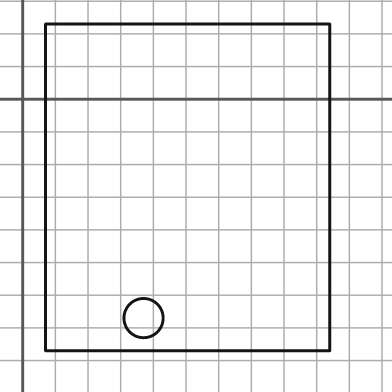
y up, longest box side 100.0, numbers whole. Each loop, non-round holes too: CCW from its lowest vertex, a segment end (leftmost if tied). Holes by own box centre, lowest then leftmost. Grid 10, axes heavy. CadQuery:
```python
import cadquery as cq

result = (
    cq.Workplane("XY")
    .moveTo(7.0, -77.0)
    .lineTo(94.0, -77.0)
    .lineTo(94.0, 23.0)
    .lineTo(7.0, 23.0)
    .close()
    .moveTo(37.0, -67.0)
    .circle(6.0)
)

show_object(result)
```